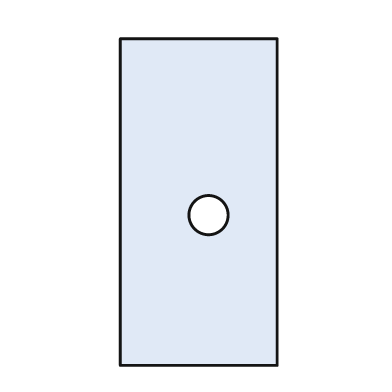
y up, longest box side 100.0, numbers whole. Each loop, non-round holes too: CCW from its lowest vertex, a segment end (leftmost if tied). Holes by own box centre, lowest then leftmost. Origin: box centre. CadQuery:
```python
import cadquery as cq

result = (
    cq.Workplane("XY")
    .moveTo(-24.0, -50.0)
    .lineTo(24.0, -50.0)
    .lineTo(24.0, 50.0)
    .lineTo(-24.0, 50.0)
    .close()
    .moveTo(3.0, -4.0)
    .circle(6.0)
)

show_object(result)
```